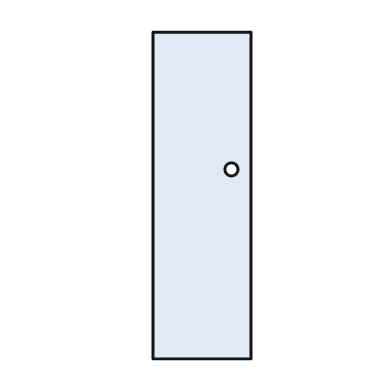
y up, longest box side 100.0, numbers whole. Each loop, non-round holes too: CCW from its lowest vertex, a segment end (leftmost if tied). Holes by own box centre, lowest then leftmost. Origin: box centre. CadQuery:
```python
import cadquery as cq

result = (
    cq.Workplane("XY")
    .moveTo(-15.0, -50.0)
    .lineTo(15.0, -50.0)
    .lineTo(15.0, 50.0)
    .lineTo(-15.0, 50.0)
    .close()
    .moveTo(9.0, 8.0)
    .circle(2.0)
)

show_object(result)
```